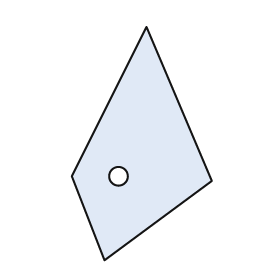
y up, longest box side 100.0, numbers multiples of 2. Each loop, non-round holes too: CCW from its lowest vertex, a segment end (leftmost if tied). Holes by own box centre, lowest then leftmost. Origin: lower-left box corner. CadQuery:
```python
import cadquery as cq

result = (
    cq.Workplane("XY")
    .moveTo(14.0, 0.0)
    .lineTo(60.0, 34.0)
    .lineTo(32.0, 100.0)
    .lineTo(0.0, 36.0)
    .close()
    .moveTo(20.0, 36.0)
    .circle(4.0)
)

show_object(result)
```